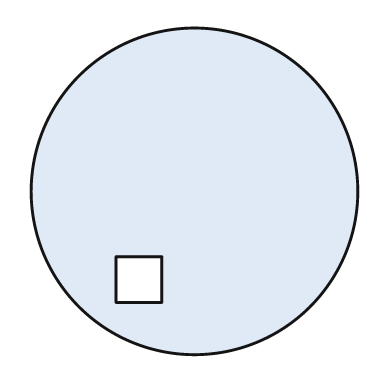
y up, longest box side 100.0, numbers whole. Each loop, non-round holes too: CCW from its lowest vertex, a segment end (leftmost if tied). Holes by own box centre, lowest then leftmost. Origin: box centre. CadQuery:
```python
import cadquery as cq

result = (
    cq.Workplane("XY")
    .moveTo(0.0, 0.0)
    .circle(50.0)
    .moveTo(-24.0, -34.0)
    .lineTo(-10.0, -34.0)
    .lineTo(-10.0, -20.0)
    .lineTo(-24.0, -20.0)
    .close()
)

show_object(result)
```